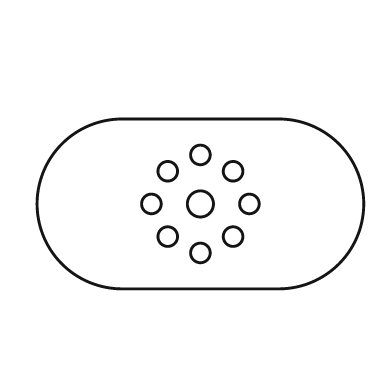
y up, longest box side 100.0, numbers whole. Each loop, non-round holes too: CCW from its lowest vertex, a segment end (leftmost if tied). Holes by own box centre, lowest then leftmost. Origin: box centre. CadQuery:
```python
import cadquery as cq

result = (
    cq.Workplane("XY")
    .moveTo(-24.0, -26.0)
    .lineTo(24.0, -26.0)
    .threePointArc((50.0, 0.0), (24.0, 26.0))
    .lineTo(-24.0, 26.0)
    .threePointArc((-50.0, 0.0), (-24.0, -26.0))
    .close()
    .moveTo(0.0, -15.0)
    .circle(3.0)
    .moveTo(-10.0, -10.0)
    .circle(3.0)
    .moveTo(10.0, -10.0)
    .circle(3.0)
    .moveTo(-15.0, 0.0)
    .circle(3.0)
    .moveTo(0.0, 0.0)
    .circle(4.0)
    .moveTo(15.0, 0.0)
    .circle(3.0)
    .moveTo(-10.0, 10.0)
    .circle(3.0)
    .moveTo(10.0, 10.0)
    .circle(3.0)
    .moveTo(0.0, 15.0)
    .circle(3.0)
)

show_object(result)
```